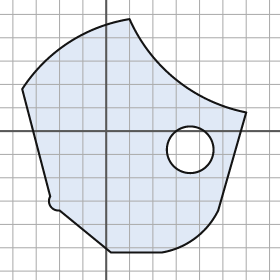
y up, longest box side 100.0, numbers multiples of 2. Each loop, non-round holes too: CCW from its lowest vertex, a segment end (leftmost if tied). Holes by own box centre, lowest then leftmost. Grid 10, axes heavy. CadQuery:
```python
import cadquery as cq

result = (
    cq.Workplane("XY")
    .moveTo(2.0, -52.0)
    .lineTo(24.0, -52.0)
    .threePointArc((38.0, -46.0), (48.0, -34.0))
    .lineTo(60.0, 8.0)
    .threePointArc((30.0, 22.0), (10.0, 48.0))
    .threePointArc((-16.0, 38.0), (-36.0, 18.0))
    .lineTo(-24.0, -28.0)
    .threePointArc((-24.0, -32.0), (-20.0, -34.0))
    .close()
    .moveTo(36.0, -8.0)
    .circle(10.0)
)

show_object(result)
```